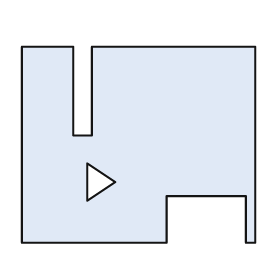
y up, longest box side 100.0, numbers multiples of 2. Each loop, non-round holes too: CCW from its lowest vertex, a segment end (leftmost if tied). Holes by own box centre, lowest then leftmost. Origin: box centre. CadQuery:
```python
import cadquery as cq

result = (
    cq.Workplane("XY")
    .moveTo(-50.0, -42.0)
    .lineTo(12.0, -42.0)
    .lineTo(12.0, -22.0)
    .lineTo(46.0, -22.0)
    .lineTo(46.0, -42.0)
    .lineTo(50.0, -42.0)
    .lineTo(50.0, 42.0)
    .lineTo(-20.0, 42.0)
    .lineTo(-20.0, 4.0)
    .lineTo(-28.0, 4.0)
    .lineTo(-28.0, 42.0)
    .lineTo(-50.0, 42.0)
    .close()
    .moveTo(-22.0, -24.0)
    .lineTo(-10.0, -16.0)
    .lineTo(-22.0, -8.0)
    .close()
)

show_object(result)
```